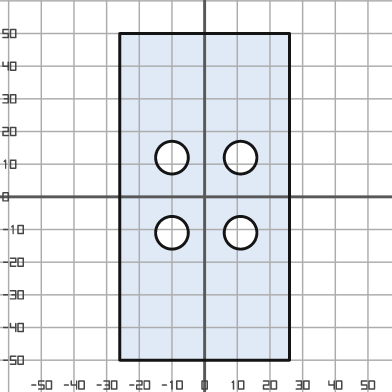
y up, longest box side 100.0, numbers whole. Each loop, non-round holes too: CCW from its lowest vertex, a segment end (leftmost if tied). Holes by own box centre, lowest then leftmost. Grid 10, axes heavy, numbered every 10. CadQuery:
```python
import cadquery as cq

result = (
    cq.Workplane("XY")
    .moveTo(-26.0, -50.0)
    .lineTo(26.0, -50.0)
    .lineTo(26.0, 50.0)
    .lineTo(-26.0, 50.0)
    .close()
    .moveTo(-10.0, -11.0)
    .circle(5.0)
    .moveTo(11.0, -11.0)
    .circle(5.0)
    .moveTo(-10.0, 12.0)
    .circle(5.0)
    .moveTo(11.0, 12.0)
    .circle(5.0)
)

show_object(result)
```